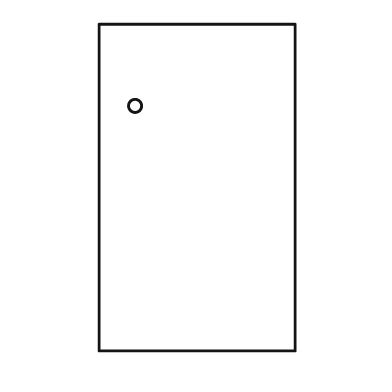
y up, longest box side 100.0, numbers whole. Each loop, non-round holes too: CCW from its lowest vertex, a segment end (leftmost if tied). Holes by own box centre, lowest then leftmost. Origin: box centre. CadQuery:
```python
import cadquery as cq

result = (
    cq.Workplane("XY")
    .moveTo(-30.0, -50.0)
    .lineTo(30.0, -50.0)
    .lineTo(30.0, 50.0)
    .lineTo(-30.0, 50.0)
    .close()
    .moveTo(-19.0, 25.0)
    .circle(2.0)
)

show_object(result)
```